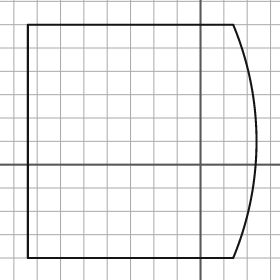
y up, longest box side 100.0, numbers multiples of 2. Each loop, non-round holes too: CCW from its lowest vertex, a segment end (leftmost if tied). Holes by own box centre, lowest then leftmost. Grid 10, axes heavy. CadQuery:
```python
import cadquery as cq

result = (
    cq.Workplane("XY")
    .moveTo(-74.0, -40.0)
    .lineTo(14.0, -40.0)
    .threePointArc((24.0, 10.0), (14.0, 60.0))
    .lineTo(-74.0, 60.0)
    .close()
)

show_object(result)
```